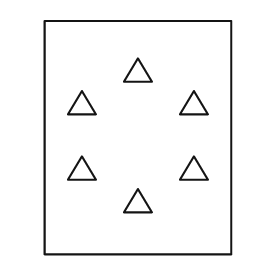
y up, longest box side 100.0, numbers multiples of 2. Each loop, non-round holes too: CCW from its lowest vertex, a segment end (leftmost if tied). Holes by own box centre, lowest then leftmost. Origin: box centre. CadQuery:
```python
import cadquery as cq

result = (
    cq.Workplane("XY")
    .moveTo(-40.0, -50.0)
    .lineTo(40.0, -50.0)
    .lineTo(40.0, 50.0)
    .lineTo(-40.0, 50.0)
    .close()
    .moveTo(-6.0, -32.0)
    .lineTo(6.0, -32.0)
    .lineTo(0.0, -22.0)
    .close()
    .moveTo(-30.0, -18.0)
    .lineTo(-18.0, -18.0)
    .lineTo(-24.0, -8.0)
    .close()
    .moveTo(18.0, -18.0)
    .lineTo(30.0, -18.0)
    .lineTo(24.0, -8.0)
    .close()
    .moveTo(-30.0, 10.0)
    .lineTo(-18.0, 10.0)
    .lineTo(-24.0, 20.0)
    .close()
    .moveTo(18.0, 10.0)
    .lineTo(30.0, 10.0)
    .lineTo(24.0, 20.0)
    .close()
    .moveTo(-6.0, 24.0)
    .lineTo(6.0, 24.0)
    .lineTo(0.0, 34.0)
    .close()
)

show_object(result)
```